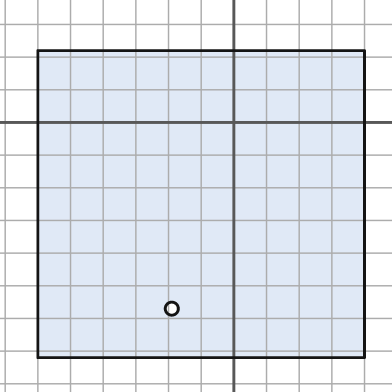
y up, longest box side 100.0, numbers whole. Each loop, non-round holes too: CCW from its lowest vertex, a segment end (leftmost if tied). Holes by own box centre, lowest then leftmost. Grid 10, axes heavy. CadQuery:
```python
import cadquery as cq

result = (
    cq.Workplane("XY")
    .moveTo(-60.0, -72.0)
    .lineTo(40.0, -72.0)
    .lineTo(40.0, 22.0)
    .lineTo(-60.0, 22.0)
    .close()
    .moveTo(-19.0, -57.0)
    .circle(2.0)
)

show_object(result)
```